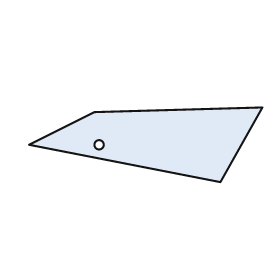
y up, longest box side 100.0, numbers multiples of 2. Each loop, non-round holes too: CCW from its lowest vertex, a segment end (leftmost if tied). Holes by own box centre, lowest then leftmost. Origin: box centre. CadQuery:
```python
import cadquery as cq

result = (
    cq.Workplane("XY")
    .moveTo(32.0, -16.0)
    .lineTo(50.0, 16.0)
    .lineTo(-22.0, 14.0)
    .lineTo(-50.0, 0.0)
    .close()
    .moveTo(-20.0, 0.0)
    .circle(2.0)
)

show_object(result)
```